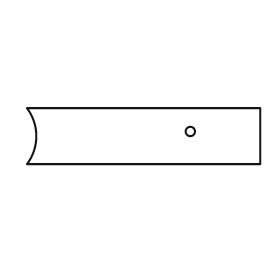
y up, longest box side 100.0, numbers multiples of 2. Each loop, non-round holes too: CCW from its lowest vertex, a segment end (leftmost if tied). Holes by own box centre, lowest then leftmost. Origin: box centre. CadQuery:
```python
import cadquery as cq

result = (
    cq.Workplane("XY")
    .moveTo(-50.0, -12.0)
    .lineTo(50.0, -12.0)
    .lineTo(50.0, 12.0)
    .lineTo(-50.0, 12.0)
    .threePointArc((-46.0, 0.0), (-50.0, -12.0))
    .close()
    .moveTo(20.0, 2.0)
    .circle(2.0)
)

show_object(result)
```